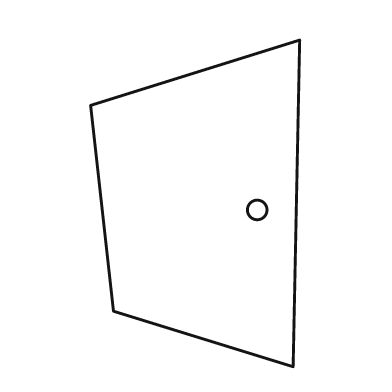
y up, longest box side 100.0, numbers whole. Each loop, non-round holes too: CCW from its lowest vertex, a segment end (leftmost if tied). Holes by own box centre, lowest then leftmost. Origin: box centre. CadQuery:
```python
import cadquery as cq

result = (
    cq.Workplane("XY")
    .moveTo(30.0, -50.0)
    .lineTo(32.0, 50.0)
    .lineTo(-32.0, 30.0)
    .lineTo(-25.0, -33.0)
    .close()
    .moveTo(19.0, -2.0)
    .circle(3.0)
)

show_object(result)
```